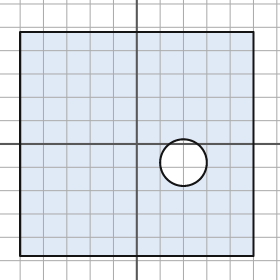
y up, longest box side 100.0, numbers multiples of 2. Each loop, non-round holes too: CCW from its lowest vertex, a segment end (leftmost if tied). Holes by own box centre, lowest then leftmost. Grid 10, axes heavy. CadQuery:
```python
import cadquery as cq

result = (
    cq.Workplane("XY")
    .moveTo(-50.0, -48.0)
    .lineTo(50.0, -48.0)
    .lineTo(50.0, 48.0)
    .lineTo(-50.0, 48.0)
    .close()
    .moveTo(20.0, -8.0)
    .circle(10.0)
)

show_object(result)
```